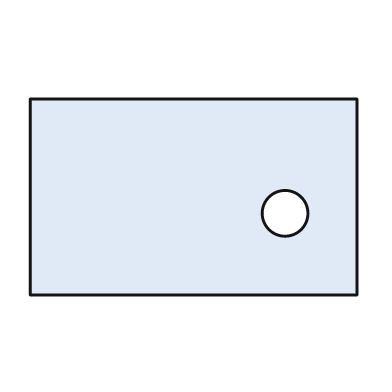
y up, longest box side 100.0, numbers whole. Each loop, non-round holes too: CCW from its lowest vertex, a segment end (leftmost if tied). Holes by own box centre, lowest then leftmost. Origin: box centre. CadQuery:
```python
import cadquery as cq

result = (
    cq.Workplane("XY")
    .moveTo(-50.0, -30.0)
    .lineTo(50.0, -30.0)
    .lineTo(50.0, 30.0)
    .lineTo(-50.0, 30.0)
    .close()
    .moveTo(28.0, -5.0)
    .circle(7.0)
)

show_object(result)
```